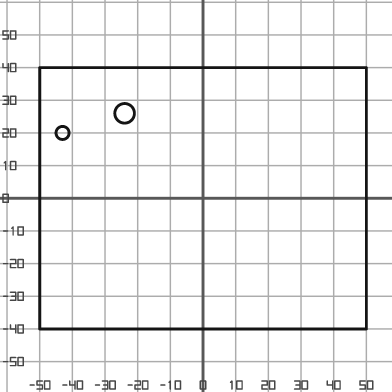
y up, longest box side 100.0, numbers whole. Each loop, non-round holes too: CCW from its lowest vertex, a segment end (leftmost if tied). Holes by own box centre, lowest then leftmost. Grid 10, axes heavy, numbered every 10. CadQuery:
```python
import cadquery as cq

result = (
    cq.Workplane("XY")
    .moveTo(-50.0, -40.0)
    .lineTo(50.0, -40.0)
    .lineTo(50.0, 40.0)
    .lineTo(-50.0, 40.0)
    .close()
    .moveTo(-43.0, 20.0)
    .circle(2.0)
    .moveTo(-24.0, 26.0)
    .circle(3.0)
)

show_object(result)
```